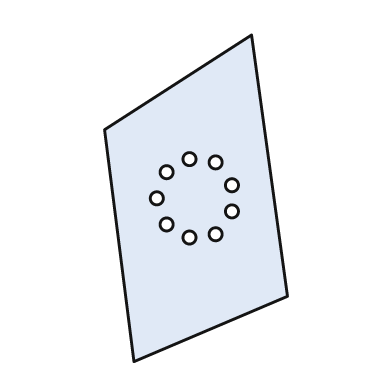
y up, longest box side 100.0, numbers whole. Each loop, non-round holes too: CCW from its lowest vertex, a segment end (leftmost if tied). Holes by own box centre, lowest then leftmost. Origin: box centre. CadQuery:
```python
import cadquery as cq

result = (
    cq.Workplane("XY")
    .moveTo(-19.0, -50.0)
    .lineTo(28.0, -30.0)
    .lineTo(17.0, 50.0)
    .lineTo(-28.0, 21.0)
    .close()
    .moveTo(-2.0, -12.0)
    .circle(2.0)
    .moveTo(6.0, -11.0)
    .circle(2.0)
    .moveTo(-9.0, -8.0)
    .circle(2.0)
    .moveTo(11.0, -4.0)
    .circle(2.0)
    .moveTo(-12.0, 0.0)
    .circle(2.0)
    .moveTo(11.0, 4.0)
    .circle(2.0)
    .moveTo(-9.0, 8.0)
    .circle(2.0)
    .moveTo(6.0, 11.0)
    .circle(2.0)
    .moveTo(-2.0, 12.0)
    .circle(2.0)
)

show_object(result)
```